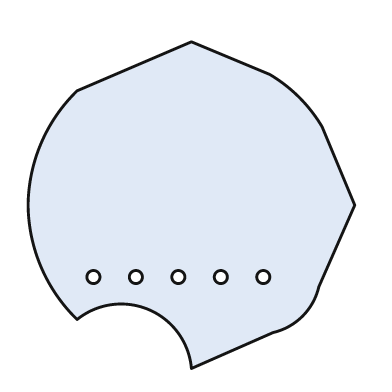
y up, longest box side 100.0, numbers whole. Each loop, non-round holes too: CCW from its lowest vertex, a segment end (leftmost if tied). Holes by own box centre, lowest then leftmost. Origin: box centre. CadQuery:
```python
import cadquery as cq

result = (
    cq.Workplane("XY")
    .moveTo(0.0, -50.0)
    .lineTo(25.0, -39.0)
    .threePointArc((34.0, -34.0), (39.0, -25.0))
    .lineTo(50.0, 0.0)
    .lineTo(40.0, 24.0)
    .threePointArc((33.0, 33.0), (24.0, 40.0))
    .lineTo(0.0, 50.0)
    .lineTo(-35.0, 35.0)
    .threePointArc((-46.0, 19.0), (-50.0, 0.0))
    .threePointArc((-46.0, -19.0), (-35.0, -35.0))
    .threePointArc((-13.0, -32.0), (0.0, -50.0))
    .close()
    .moveTo(-30.0, -22.0)
    .circle(2.0)
    .moveTo(-17.0, -22.0)
    .circle(2.0)
    .moveTo(-4.0, -22.0)
    .circle(2.0)
    .moveTo(9.0, -22.0)
    .circle(2.0)
    .moveTo(22.0, -22.0)
    .circle(2.0)
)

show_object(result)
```